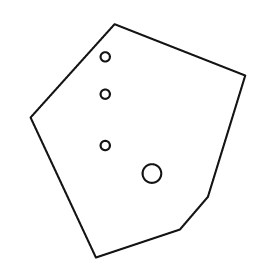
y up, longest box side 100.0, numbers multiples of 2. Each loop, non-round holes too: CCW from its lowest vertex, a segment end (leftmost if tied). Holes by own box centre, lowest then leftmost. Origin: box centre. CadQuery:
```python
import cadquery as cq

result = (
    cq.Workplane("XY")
    .moveTo(-18.0, -50.0)
    .lineTo(18.0, -38.0)
    .lineTo(30.0, -24.0)
    .lineTo(46.0, 28.0)
    .lineTo(-10.0, 50.0)
    .lineTo(-46.0, 10.0)
    .close()
    .moveTo(6.0, -14.0)
    .circle(4.0)
    .moveTo(-14.0, -2.0)
    .circle(2.0)
    .moveTo(-14.0, 20.0)
    .circle(2.0)
    .moveTo(-14.0, 36.0)
    .circle(2.0)
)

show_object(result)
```